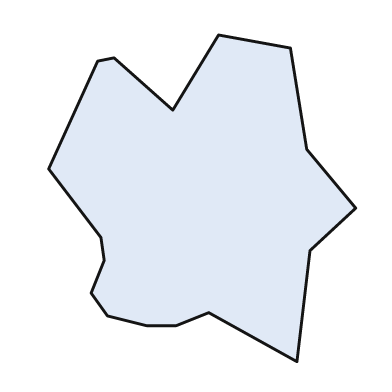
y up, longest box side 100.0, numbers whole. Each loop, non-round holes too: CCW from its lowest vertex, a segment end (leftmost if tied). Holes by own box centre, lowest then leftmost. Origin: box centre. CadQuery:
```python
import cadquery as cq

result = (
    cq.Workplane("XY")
    .moveTo(29.0, -50.0)
    .lineTo(33.0, -16.0)
    .lineTo(47.0, -3.0)
    .lineTo(32.0, 15.0)
    .lineTo(27.0, 46.0)
    .lineTo(5.0, 50.0)
    .lineTo(-9.0, 27.0)
    .lineTo(-27.0, 43.0)
    .lineTo(-32.0, 42.0)
    .lineTo(-47.0, 9.0)
    .lineTo(-31.0, -12.0)
    .lineTo(-30.0, -19.0)
    .lineTo(-34.0, -29.0)
    .lineTo(-29.0, -36.0)
    .lineTo(-17.0, -39.0)
    .lineTo(-8.0, -39.0)
    .lineTo(2.0, -35.0)
    .close()
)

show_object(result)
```